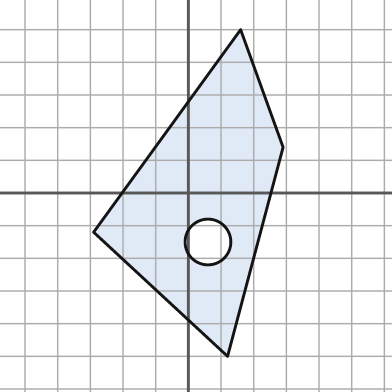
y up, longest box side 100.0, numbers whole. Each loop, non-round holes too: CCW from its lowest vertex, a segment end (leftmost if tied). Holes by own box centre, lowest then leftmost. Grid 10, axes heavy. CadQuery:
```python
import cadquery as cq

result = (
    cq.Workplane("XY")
    .moveTo(12.0, -50.0)
    .lineTo(29.0, 14.0)
    .lineTo(16.0, 50.0)
    .lineTo(-29.0, -12.0)
    .close()
    .moveTo(6.0, -15.0)
    .circle(7.0)
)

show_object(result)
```